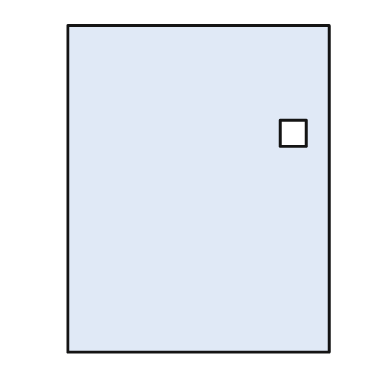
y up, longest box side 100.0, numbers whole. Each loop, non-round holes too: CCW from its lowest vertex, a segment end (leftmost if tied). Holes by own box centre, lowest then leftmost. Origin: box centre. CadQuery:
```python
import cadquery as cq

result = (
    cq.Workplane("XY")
    .moveTo(-40.0, -50.0)
    .lineTo(40.0, -50.0)
    .lineTo(40.0, 50.0)
    .lineTo(-40.0, 50.0)
    .close()
    .moveTo(25.0, 13.0)
    .lineTo(33.0, 13.0)
    .lineTo(33.0, 21.0)
    .lineTo(25.0, 21.0)
    .close()
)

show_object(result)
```